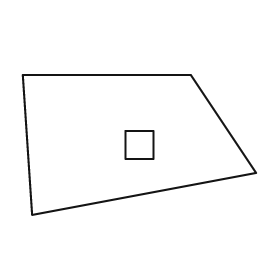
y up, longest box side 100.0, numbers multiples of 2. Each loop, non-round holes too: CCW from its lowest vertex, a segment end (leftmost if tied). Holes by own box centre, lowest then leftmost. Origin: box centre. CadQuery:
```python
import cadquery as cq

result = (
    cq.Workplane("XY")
    .moveTo(-46.0, -30.0)
    .lineTo(50.0, -12.0)
    .lineTo(22.0, 30.0)
    .lineTo(-50.0, 30.0)
    .close()
    .moveTo(-6.0, -6.0)
    .lineTo(6.0, -6.0)
    .lineTo(6.0, 6.0)
    .lineTo(-6.0, 6.0)
    .close()
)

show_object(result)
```